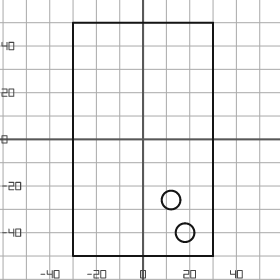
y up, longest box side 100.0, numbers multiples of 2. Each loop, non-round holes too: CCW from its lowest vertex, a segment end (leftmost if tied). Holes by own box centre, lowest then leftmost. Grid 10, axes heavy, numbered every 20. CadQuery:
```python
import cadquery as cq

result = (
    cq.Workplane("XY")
    .moveTo(-30.0, -50.0)
    .lineTo(30.0, -50.0)
    .lineTo(30.0, 50.0)
    .lineTo(-30.0, 50.0)
    .close()
    .moveTo(18.0, -40.0)
    .circle(4.0)
    .moveTo(12.0, -26.0)
    .circle(4.0)
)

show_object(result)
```